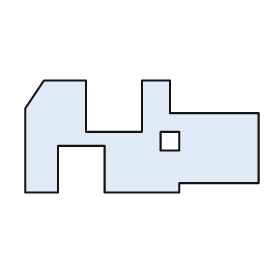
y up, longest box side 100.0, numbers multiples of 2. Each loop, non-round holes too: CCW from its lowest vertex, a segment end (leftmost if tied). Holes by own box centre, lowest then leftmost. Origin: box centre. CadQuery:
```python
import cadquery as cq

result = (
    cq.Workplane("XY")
    .moveTo(-50.0, -24.0)
    .lineTo(-36.0, -24.0)
    .lineTo(-36.0, -4.0)
    .lineTo(-16.0, -4.0)
    .lineTo(-16.0, -24.0)
    .lineTo(16.0, -24.0)
    .lineTo(16.0, -20.0)
    .lineTo(50.0, -20.0)
    .lineTo(50.0, 10.0)
    .lineTo(12.0, 10.0)
    .lineTo(12.0, 24.0)
    .lineTo(0.0, 24.0)
    .lineTo(0.0, 2.0)
    .lineTo(-24.0, 2.0)
    .lineTo(-24.0, 24.0)
    .lineTo(-42.0, 24.0)
    .lineTo(-50.0, 12.0)
    .close()
    .moveTo(8.0, -6.0)
    .lineTo(16.0, -6.0)
    .lineTo(16.0, 2.0)
    .lineTo(8.0, 2.0)
    .close()
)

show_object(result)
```